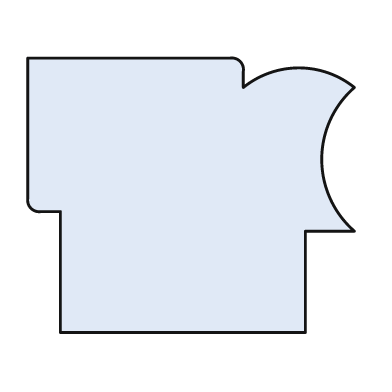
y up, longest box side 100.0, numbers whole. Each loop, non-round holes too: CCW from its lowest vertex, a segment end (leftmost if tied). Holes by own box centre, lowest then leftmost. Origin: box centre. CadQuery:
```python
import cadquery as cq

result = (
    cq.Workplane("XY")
    .moveTo(-40.0, -42.0)
    .lineTo(35.0, -42.0)
    .lineTo(35.0, -11.0)
    .lineTo(50.0, -11.0)
    .threePointArc((40.0, 11.0), (50.0, 33.0))
    .threePointArc((33.0, 39.0), (16.0, 33.0))
    .lineTo(16.0, 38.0)
    .threePointArc((15.0, 41.0), (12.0, 42.0))
    .lineTo(-50.0, 42.0)
    .lineTo(-50.0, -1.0)
    .threePointArc((-49.0, -4.0), (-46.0, -5.0))
    .lineTo(-40.0, -5.0)
    .close()
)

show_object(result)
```